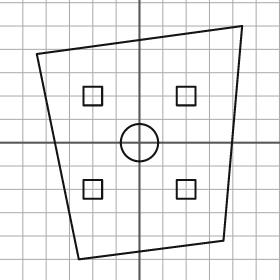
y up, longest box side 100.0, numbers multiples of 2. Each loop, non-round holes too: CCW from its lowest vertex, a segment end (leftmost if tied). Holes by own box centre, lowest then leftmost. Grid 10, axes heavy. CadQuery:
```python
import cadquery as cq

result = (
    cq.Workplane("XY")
    .moveTo(-26.0, -50.0)
    .lineTo(36.0, -42.0)
    .lineTo(44.0, 50.0)
    .lineTo(-44.0, 38.0)
    .close()
    .moveTo(-24.0, -24.0)
    .lineTo(-16.0, -24.0)
    .lineTo(-16.0, -16.0)
    .lineTo(-24.0, -16.0)
    .close()
    .moveTo(16.0, -24.0)
    .lineTo(24.0, -24.0)
    .lineTo(24.0, -16.0)
    .lineTo(16.0, -16.0)
    .close()
    .moveTo(0.0, 0.0)
    .circle(8.0)
    .moveTo(-24.0, 16.0)
    .lineTo(-16.0, 16.0)
    .lineTo(-16.0, 24.0)
    .lineTo(-24.0, 24.0)
    .close()
    .moveTo(16.0, 16.0)
    .lineTo(24.0, 16.0)
    .lineTo(24.0, 24.0)
    .lineTo(16.0, 24.0)
    .close()
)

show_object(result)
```